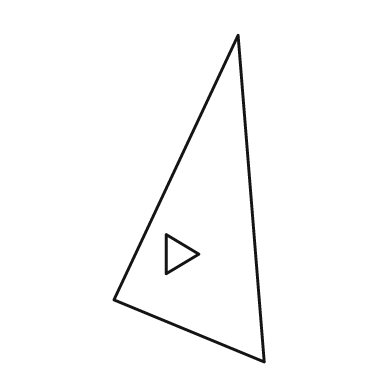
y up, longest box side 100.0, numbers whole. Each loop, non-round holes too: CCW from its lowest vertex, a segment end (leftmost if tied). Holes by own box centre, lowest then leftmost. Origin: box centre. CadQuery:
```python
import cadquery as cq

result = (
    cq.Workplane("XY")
    .moveTo(23.0, -50.0)
    .lineTo(15.0, 50.0)
    .lineTo(-23.0, -31.0)
    .close()
    .moveTo(-7.0, -23.0)
    .lineTo(3.0, -17.0)
    .lineTo(-7.0, -11.0)
    .close()
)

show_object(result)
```